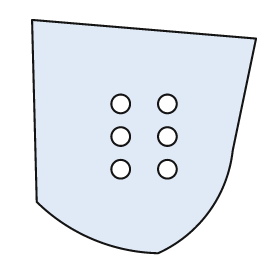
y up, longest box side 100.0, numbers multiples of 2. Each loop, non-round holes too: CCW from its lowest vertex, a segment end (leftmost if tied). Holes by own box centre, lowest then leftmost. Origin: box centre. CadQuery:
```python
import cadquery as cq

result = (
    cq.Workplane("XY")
    .moveTo(6.0, -50.0)
    .threePointArc((28.0, -32.0), (38.0, -6.0))
    .lineTo(48.0, 42.0)
    .lineTo(-48.0, 50.0)
    .lineTo(-46.0, -28.0)
    .threePointArc((-22.0, -44.0), (6.0, -50.0))
    .close()
    .moveTo(-10.0, -14.0)
    .circle(4.0)
    .moveTo(10.0, -14.0)
    .circle(4.0)
    .moveTo(-10.0, 0.0)
    .circle(4.0)
    .moveTo(10.0, 0.0)
    .circle(4.0)
    .moveTo(-10.0, 14.0)
    .circle(4.0)
    .moveTo(10.0, 14.0)
    .circle(4.0)
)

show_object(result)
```